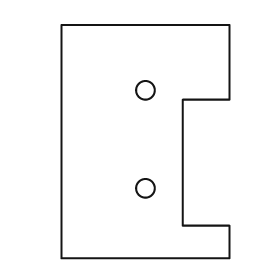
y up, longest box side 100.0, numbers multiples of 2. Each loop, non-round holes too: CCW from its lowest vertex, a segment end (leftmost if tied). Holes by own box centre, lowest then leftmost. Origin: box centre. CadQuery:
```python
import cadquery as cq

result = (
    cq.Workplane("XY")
    .moveTo(-36.0, -50.0)
    .lineTo(36.0, -50.0)
    .lineTo(36.0, -36.0)
    .lineTo(16.0, -36.0)
    .lineTo(16.0, 18.0)
    .lineTo(36.0, 18.0)
    .lineTo(36.0, 50.0)
    .lineTo(-36.0, 50.0)
    .close()
    .moveTo(0.0, -20.0)
    .circle(4.0)
    .moveTo(0.0, 22.0)
    .circle(4.0)
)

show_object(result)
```